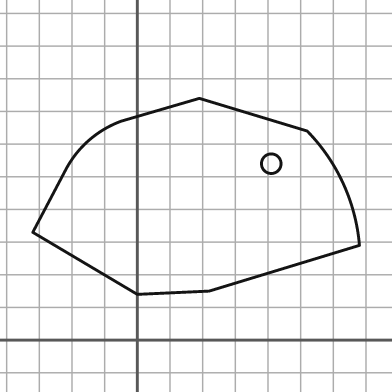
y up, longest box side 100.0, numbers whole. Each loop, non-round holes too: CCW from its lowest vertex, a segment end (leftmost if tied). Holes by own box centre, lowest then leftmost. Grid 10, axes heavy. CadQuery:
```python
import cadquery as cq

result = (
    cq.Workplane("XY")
    .moveTo(0.0, 14.0)
    .lineTo(22.0, 15.0)
    .lineTo(68.0, 29.0)
    .threePointArc((63.0, 48.0), (52.0, 64.0))
    .lineTo(19.0, 74.0)
    .lineTo(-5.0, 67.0)
    .threePointArc((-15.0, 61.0), (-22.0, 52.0))
    .lineTo(-32.0, 33.0)
    .close()
    .moveTo(41.0, 54.0)
    .circle(3.0)
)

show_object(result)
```